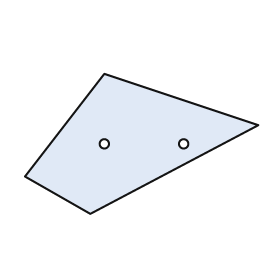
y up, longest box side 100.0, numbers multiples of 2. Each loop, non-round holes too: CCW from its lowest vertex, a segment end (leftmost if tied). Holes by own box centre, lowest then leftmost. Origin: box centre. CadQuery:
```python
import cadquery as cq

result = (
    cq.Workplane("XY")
    .moveTo(-22.0, -30.0)
    .lineTo(50.0, 8.0)
    .lineTo(-16.0, 30.0)
    .lineTo(-50.0, -14.0)
    .close()
    .moveTo(-16.0, 0.0)
    .circle(2.0)
    .moveTo(18.0, 0.0)
    .circle(2.0)
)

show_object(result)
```